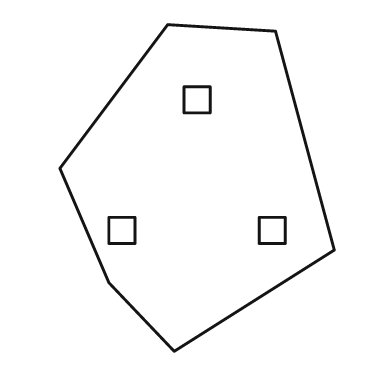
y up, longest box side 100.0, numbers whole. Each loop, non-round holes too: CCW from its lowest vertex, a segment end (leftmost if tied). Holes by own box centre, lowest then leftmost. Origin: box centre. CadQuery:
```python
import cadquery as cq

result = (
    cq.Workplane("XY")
    .moveTo(-7.0, -50.0)
    .lineTo(42.0, -19.0)
    .lineTo(24.0, 48.0)
    .lineTo(-9.0, 50.0)
    .lineTo(-42.0, 6.0)
    .lineTo(-27.0, -29.0)
    .close()
    .moveTo(-27.0, -17.0)
    .lineTo(-19.0, -17.0)
    .lineTo(-19.0, -9.0)
    .lineTo(-27.0, -9.0)
    .close()
    .moveTo(19.0, -17.0)
    .lineTo(27.0, -17.0)
    .lineTo(27.0, -9.0)
    .lineTo(19.0, -9.0)
    .close()
    .moveTo(-4.0, 23.0)
    .lineTo(4.0, 23.0)
    .lineTo(4.0, 31.0)
    .lineTo(-4.0, 31.0)
    .close()
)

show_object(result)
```